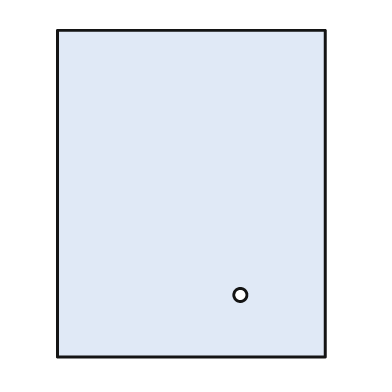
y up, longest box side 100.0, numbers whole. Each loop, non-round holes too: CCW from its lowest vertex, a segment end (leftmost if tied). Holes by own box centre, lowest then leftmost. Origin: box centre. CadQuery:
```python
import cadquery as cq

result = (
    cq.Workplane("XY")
    .moveTo(-41.0, -50.0)
    .lineTo(41.0, -50.0)
    .lineTo(41.0, 50.0)
    .lineTo(-41.0, 50.0)
    .close()
    .moveTo(15.0, -31.0)
    .circle(2.0)
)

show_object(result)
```